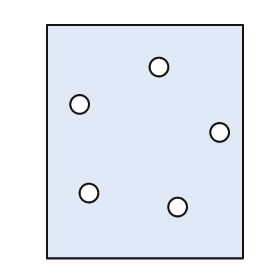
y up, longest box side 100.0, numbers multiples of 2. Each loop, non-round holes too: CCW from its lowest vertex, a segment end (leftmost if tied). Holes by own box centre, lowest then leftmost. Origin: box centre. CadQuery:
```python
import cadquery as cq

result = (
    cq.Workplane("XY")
    .moveTo(-42.0, -50.0)
    .lineTo(42.0, -50.0)
    .lineTo(42.0, 50.0)
    .lineTo(-42.0, 50.0)
    .close()
    .moveTo(14.0, -28.0)
    .circle(4.0)
    .moveTo(-24.0, -22.0)
    .circle(4.0)
    .moveTo(32.0, 4.0)
    .circle(4.0)
    .moveTo(-28.0, 16.0)
    .circle(4.0)
    .moveTo(6.0, 32.0)
    .circle(4.0)
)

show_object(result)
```